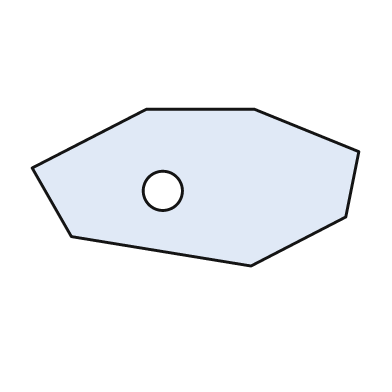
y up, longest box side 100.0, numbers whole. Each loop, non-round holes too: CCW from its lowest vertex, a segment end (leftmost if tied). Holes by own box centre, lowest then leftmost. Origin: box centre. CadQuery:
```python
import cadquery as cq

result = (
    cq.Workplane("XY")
    .moveTo(17.0, -24.0)
    .lineTo(46.0, -9.0)
    .lineTo(50.0, 11.0)
    .lineTo(18.0, 24.0)
    .lineTo(-15.0, 24.0)
    .lineTo(-50.0, 6.0)
    .lineTo(-38.0, -15.0)
    .close()
    .moveTo(-10.0, -1.0)
    .circle(6.0)
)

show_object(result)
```